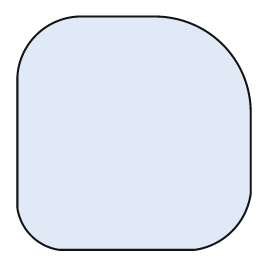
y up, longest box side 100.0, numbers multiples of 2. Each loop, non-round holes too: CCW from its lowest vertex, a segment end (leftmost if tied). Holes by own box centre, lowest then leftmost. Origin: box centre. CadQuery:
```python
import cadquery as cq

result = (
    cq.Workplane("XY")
    .moveTo(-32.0, -50.0)
    .lineTo(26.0, -50.0)
    .threePointArc((42.0, -42.0), (50.0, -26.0))
    .lineTo(50.0, 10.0)
    .threePointArc((38.0, 38.0), (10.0, 50.0))
    .lineTo(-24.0, 50.0)
    .threePointArc((-42.0, 42.0), (-50.0, 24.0))
    .lineTo(-50.0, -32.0)
    .threePointArc((-44.0, -44.0), (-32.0, -50.0))
    .close()
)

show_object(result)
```